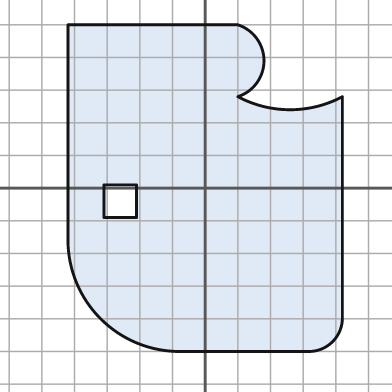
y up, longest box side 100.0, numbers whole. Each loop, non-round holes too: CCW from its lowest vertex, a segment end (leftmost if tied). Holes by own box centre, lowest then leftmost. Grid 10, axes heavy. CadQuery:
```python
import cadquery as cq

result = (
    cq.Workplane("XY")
    .moveTo(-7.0, -50.0)
    .lineTo(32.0, -50.0)
    .threePointArc((39.0, -47.0), (42.0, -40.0))
    .lineTo(42.0, 28.0)
    .threePointArc((26.0, 24.0), (10.0, 28.0))
    .threePointArc((18.0, 39.0), (10.0, 50.0))
    .lineTo(-42.0, 50.0)
    .lineTo(-42.0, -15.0)
    .threePointArc((-32.0, -40.0), (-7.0, -50.0))
    .close()
    .moveTo(-31.0, -9.0)
    .lineTo(-21.0, -9.0)
    .lineTo(-21.0, 1.0)
    .lineTo(-31.0, 1.0)
    .close()
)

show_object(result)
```